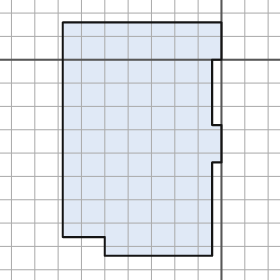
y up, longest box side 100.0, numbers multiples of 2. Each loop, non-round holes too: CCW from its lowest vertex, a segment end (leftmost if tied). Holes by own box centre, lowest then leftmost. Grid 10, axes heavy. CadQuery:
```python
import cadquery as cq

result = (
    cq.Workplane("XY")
    .moveTo(-50.0, -84.0)
    .lineTo(-4.0, -84.0)
    .lineTo(-4.0, -44.0)
    .lineTo(0.0, -44.0)
    .lineTo(0.0, -28.0)
    .lineTo(-4.0, -28.0)
    .lineTo(-4.0, 0.0)
    .lineTo(0.0, 0.0)
    .lineTo(0.0, 16.0)
    .lineTo(-68.0, 16.0)
    .lineTo(-68.0, -76.0)
    .lineTo(-50.0, -76.0)
    .close()
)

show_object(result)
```